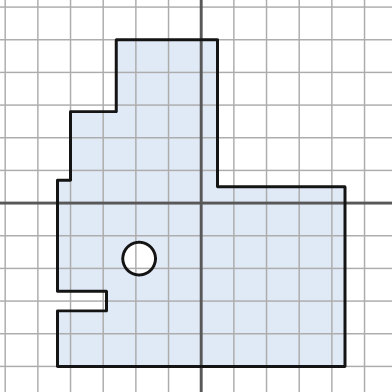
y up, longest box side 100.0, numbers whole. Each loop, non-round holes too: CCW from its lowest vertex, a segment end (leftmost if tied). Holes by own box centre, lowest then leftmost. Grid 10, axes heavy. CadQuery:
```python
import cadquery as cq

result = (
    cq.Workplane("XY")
    .moveTo(-44.0, -50.0)
    .lineTo(44.0, -50.0)
    .lineTo(44.0, 5.0)
    .lineTo(5.0, 5.0)
    .lineTo(5.0, 50.0)
    .lineTo(-26.0, 50.0)
    .lineTo(-26.0, 28.0)
    .lineTo(-40.0, 28.0)
    .lineTo(-40.0, 7.0)
    .lineTo(-44.0, 7.0)
    .lineTo(-44.0, -27.0)
    .lineTo(-29.0, -27.0)
    .lineTo(-29.0, -33.0)
    .lineTo(-44.0, -33.0)
    .close()
    .moveTo(-19.0, -17.0)
    .circle(5.0)
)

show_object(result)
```